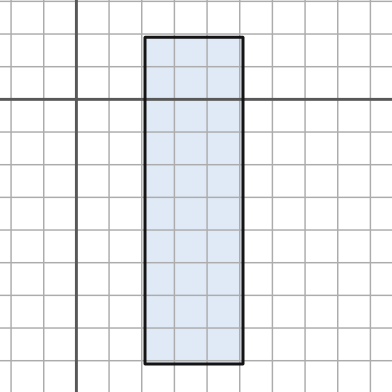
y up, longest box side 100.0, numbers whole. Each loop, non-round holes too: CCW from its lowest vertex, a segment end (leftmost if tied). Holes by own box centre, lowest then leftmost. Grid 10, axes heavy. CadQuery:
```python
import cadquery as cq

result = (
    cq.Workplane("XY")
    .moveTo(21.0, -81.0)
    .lineTo(51.0, -81.0)
    .lineTo(51.0, 19.0)
    .lineTo(21.0, 19.0)
    .close()
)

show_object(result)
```